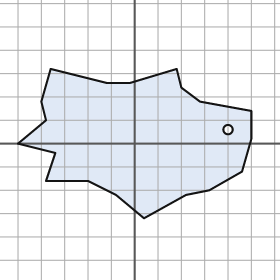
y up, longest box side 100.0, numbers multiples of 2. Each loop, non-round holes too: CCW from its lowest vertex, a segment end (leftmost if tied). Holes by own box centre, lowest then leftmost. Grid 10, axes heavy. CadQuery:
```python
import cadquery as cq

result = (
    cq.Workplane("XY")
    .moveTo(4.0, -32.0)
    .lineTo(22.0, -22.0)
    .lineTo(32.0, -20.0)
    .lineTo(46.0, -12.0)
    .lineTo(50.0, 2.0)
    .lineTo(50.0, 14.0)
    .lineTo(28.0, 18.0)
    .lineTo(20.0, 24.0)
    .lineTo(18.0, 32.0)
    .lineTo(-2.0, 26.0)
    .lineTo(-12.0, 26.0)
    .lineTo(-36.0, 32.0)
    .lineTo(-40.0, 18.0)
    .lineTo(-38.0, 10.0)
    .lineTo(-50.0, 0.0)
    .lineTo(-34.0, -4.0)
    .lineTo(-38.0, -16.0)
    .lineTo(-20.0, -16.0)
    .lineTo(-8.0, -22.0)
    .close()
    .moveTo(40.0, 6.0)
    .circle(2.0)
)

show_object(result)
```